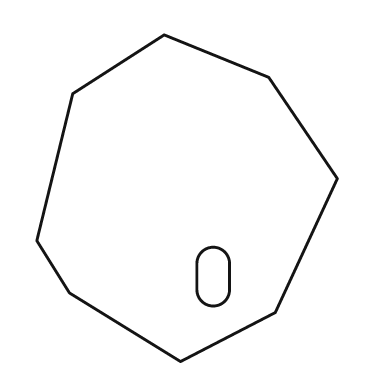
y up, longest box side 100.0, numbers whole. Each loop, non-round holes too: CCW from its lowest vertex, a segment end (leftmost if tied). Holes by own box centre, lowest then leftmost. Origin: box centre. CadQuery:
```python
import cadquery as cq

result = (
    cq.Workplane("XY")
    .moveTo(-2.0, -50.0)
    .lineTo(27.0, -35.0)
    .lineTo(46.0, 6.0)
    .lineTo(25.0, 37.0)
    .lineTo(-7.0, 50.0)
    .lineTo(-35.0, 32.0)
    .lineTo(-46.0, -13.0)
    .lineTo(-36.0, -29.0)
    .close()
    .moveTo(3.0, -28.0)
    .threePointArc((8.0, -33.0), (13.0, -28.0))
    .lineTo(13.0, -20.0)
    .threePointArc((8.0, -15.0), (3.0, -20.0))
    .close()
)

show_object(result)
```